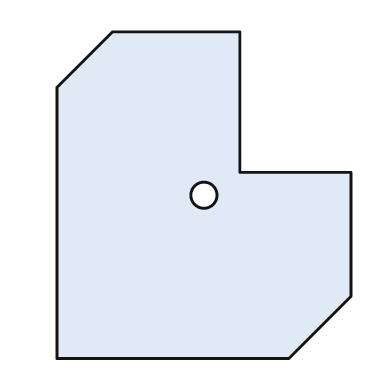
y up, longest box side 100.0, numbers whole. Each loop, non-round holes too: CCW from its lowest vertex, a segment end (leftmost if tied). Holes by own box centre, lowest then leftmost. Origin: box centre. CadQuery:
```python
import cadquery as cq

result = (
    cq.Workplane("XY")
    .moveTo(-45.0, -50.0)
    .lineTo(26.0, -50.0)
    .lineTo(45.0, -31.0)
    .lineTo(45.0, 7.0)
    .lineTo(11.0, 7.0)
    .lineTo(11.0, 50.0)
    .lineTo(-28.0, 50.0)
    .lineTo(-45.0, 33.0)
    .close()
    .moveTo(0.0, 0.0)
    .circle(4.0)
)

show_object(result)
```